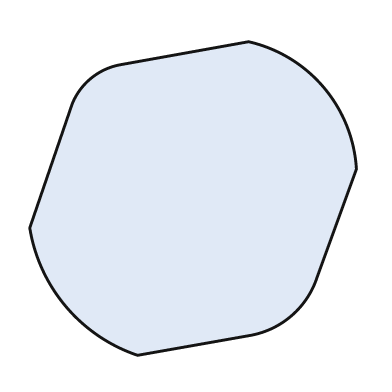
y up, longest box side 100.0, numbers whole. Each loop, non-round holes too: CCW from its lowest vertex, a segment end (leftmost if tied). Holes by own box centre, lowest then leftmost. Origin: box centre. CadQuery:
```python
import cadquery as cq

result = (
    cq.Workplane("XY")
    .moveTo(-17.0, -48.0)
    .lineTo(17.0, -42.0)
    .threePointArc((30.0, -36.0), (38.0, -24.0))
    .lineTo(50.0, 9.0)
    .threePointArc((40.0, 34.0), (17.0, 48.0))
    .lineTo(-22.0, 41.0)
    .threePointArc((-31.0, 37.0), (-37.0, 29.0))
    .lineTo(-50.0, -9.0)
    .threePointArc((-39.0, -33.0), (-17.0, -48.0))
    .close()
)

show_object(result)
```